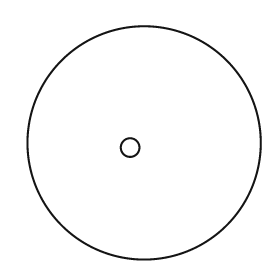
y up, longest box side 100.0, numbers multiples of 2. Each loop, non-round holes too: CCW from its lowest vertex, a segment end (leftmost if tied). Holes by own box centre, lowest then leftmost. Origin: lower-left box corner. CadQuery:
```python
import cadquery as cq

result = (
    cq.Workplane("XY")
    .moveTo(50.0, 50.0)
    .circle(50.0)
    .moveTo(44.0, 48.0)
    .circle(4.0)
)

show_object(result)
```